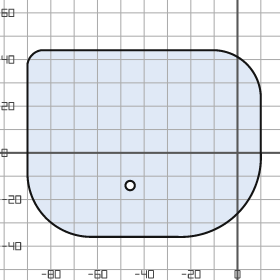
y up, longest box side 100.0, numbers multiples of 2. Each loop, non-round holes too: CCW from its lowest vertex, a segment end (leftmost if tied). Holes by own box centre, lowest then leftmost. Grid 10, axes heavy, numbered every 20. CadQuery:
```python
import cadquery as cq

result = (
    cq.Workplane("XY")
    .moveTo(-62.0, -36.0)
    .lineTo(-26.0, -36.0)
    .threePointArc((0.0, -26.0), (10.0, 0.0))
    .lineTo(10.0, 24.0)
    .threePointArc((4.0, 38.0), (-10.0, 44.0))
    .lineTo(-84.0, 44.0)
    .threePointArc((-88.0, 42.0), (-90.0, 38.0))
    .lineTo(-90.0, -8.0)
    .threePointArc((-82.0, -28.0), (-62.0, -36.0))
    .close()
    .moveTo(-46.0, -14.0)
    .circle(2.0)
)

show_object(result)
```